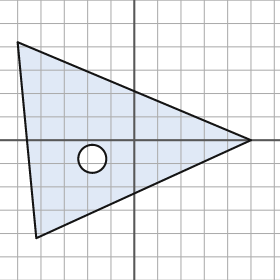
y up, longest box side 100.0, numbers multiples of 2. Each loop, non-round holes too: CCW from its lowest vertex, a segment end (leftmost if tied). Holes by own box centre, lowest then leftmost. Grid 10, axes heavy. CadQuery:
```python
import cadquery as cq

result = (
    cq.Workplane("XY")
    .moveTo(-42.0, -42.0)
    .lineTo(50.0, 0.0)
    .lineTo(-50.0, 42.0)
    .close()
    .moveTo(-18.0, -8.0)
    .circle(6.0)
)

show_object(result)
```